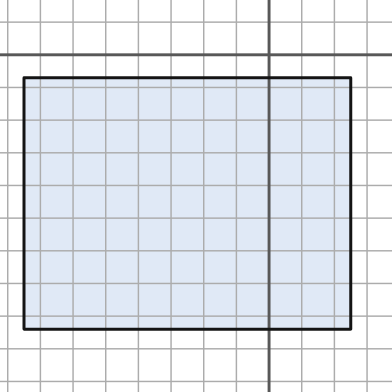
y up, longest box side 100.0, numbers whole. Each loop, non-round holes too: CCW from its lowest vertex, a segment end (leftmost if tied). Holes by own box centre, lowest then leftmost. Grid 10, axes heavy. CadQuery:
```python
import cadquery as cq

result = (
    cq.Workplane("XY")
    .moveTo(-75.0, -84.0)
    .lineTo(25.0, -84.0)
    .lineTo(25.0, -7.0)
    .lineTo(-75.0, -7.0)
    .close()
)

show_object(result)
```